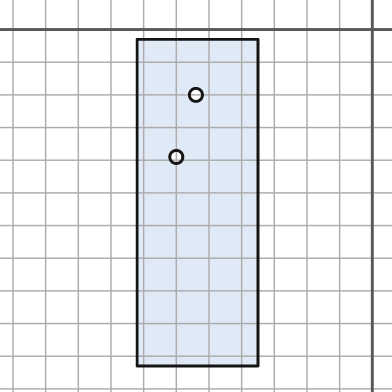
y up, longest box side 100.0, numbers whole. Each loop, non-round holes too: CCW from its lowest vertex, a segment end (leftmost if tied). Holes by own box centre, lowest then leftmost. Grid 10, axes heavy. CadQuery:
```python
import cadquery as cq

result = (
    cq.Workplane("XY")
    .moveTo(-72.0, -103.0)
    .lineTo(-35.0, -103.0)
    .lineTo(-35.0, -3.0)
    .lineTo(-72.0, -3.0)
    .close()
    .moveTo(-60.0, -39.0)
    .circle(2.0)
    .moveTo(-54.0, -20.0)
    .circle(2.0)
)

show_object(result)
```